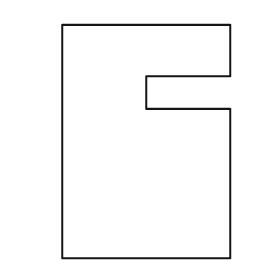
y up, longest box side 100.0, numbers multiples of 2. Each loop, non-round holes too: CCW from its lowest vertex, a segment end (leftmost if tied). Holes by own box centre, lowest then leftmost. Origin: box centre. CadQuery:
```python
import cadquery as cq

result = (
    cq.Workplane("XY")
    .moveTo(-36.0, -50.0)
    .lineTo(36.0, -50.0)
    .lineTo(36.0, 14.0)
    .lineTo(0.0, 14.0)
    .lineTo(0.0, 28.0)
    .lineTo(36.0, 28.0)
    .lineTo(36.0, 50.0)
    .lineTo(-36.0, 50.0)
    .close()
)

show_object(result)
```